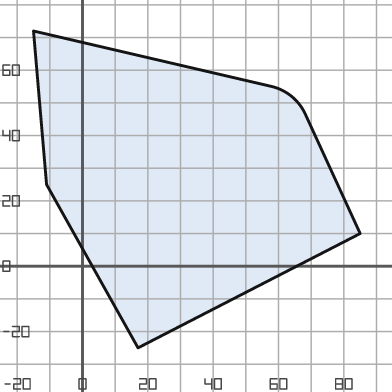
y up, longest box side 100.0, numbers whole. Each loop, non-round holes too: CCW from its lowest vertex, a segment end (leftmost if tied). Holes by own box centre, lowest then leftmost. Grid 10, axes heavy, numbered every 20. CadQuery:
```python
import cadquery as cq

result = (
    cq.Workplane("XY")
    .moveTo(17.0, -25.0)
    .lineTo(85.0, 10.0)
    .lineTo(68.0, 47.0)
    .threePointArc((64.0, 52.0), (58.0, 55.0))
    .lineTo(-15.0, 72.0)
    .lineTo(-11.0, 25.0)
    .close()
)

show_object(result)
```